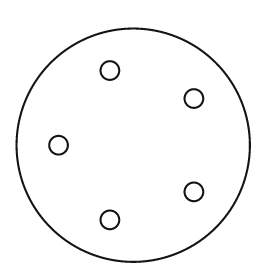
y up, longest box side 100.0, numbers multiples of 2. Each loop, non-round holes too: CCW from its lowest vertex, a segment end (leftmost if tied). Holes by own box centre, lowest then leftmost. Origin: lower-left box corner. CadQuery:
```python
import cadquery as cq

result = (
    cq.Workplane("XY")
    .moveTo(50.0, 50.0)
    .circle(50.0)
    .moveTo(40.0, 18.0)
    .circle(4.0)
    .moveTo(76.0, 30.0)
    .circle(4.0)
    .moveTo(18.0, 50.0)
    .circle(4.0)
    .moveTo(76.0, 70.0)
    .circle(4.0)
    .moveTo(40.0, 82.0)
    .circle(4.0)
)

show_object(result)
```